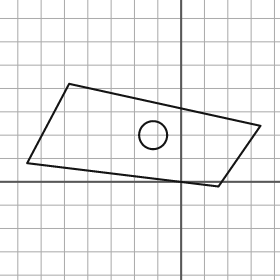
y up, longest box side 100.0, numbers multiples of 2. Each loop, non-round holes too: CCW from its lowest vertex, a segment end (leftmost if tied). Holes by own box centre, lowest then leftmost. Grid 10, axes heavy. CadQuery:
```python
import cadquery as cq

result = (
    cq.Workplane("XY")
    .moveTo(16.0, -2.0)
    .lineTo(34.0, 24.0)
    .lineTo(-48.0, 42.0)
    .lineTo(-66.0, 8.0)
    .close()
    .moveTo(-12.0, 20.0)
    .circle(6.0)
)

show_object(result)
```